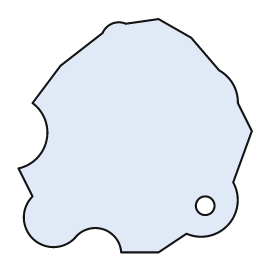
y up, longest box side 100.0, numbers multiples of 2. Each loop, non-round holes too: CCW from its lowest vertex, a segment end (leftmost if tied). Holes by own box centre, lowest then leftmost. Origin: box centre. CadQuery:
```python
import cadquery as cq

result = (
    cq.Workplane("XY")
    .moveTo(-6.0, -50.0)
    .lineTo(10.0, -50.0)
    .lineTo(22.0, -42.0)
    .threePointArc((40.0, -38.0), (42.0, -20.0))
    .lineTo(50.0, 2.0)
    .lineTo(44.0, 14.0)
    .threePointArc((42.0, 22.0), (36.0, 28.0))
    .lineTo(24.0, 42.0)
    .lineTo(10.0, 50.0)
    .lineTo(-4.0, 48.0)
    .threePointArc((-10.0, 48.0), (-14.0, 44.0))
    .lineTo(-32.0, 30.0)
    .lineTo(-44.0, 14.0)
    .threePointArc((-38.0, -2.0), (-50.0, -14.0))
    .lineTo(-44.0, -26.0)
    .threePointArc((-44.0, -44.0), (-26.0, -44.0))
    .threePointArc((-14.0, -40.0), (-6.0, -50.0))
    .close()
    .moveTo(30.0, -30.0)
    .circle(4.0)
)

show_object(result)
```